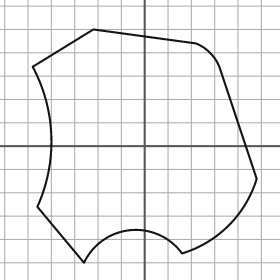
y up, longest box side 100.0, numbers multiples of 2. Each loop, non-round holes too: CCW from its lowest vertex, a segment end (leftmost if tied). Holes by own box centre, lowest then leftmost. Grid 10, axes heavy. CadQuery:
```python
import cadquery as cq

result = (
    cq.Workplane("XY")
    .moveTo(-26.0, -50.0)
    .threePointArc((-6.0, -36.0), (16.0, -46.0))
    .threePointArc((36.0, -34.0), (48.0, -14.0))
    .lineTo(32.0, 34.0)
    .threePointArc((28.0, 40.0), (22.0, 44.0))
    .lineTo(-22.0, 50.0)
    .lineTo(-48.0, 34.0)
    .threePointArc((-40.0, 4.0), (-46.0, -26.0))
    .close()
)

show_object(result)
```